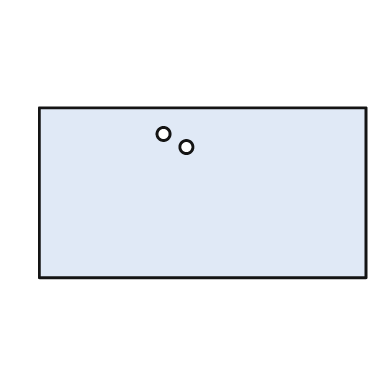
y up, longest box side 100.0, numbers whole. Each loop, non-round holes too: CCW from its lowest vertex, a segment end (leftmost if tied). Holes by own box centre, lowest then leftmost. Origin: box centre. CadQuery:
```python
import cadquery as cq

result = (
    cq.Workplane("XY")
    .moveTo(-50.0, -26.0)
    .lineTo(50.0, -26.0)
    .lineTo(50.0, 26.0)
    .lineTo(-50.0, 26.0)
    .close()
    .moveTo(-5.0, 14.0)
    .circle(2.0)
    .moveTo(-12.0, 18.0)
    .circle(2.0)
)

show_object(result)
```